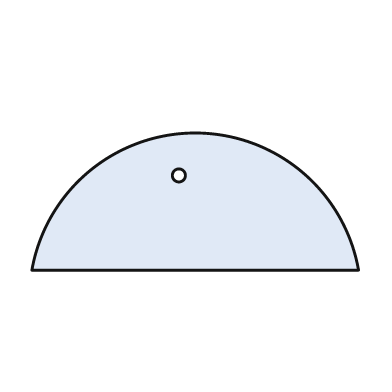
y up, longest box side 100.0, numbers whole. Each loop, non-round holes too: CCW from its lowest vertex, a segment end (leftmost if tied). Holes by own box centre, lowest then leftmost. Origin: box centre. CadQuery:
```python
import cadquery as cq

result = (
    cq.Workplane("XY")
    .moveTo(-50.0, -21.0)
    .lineTo(50.0, -21.0)
    .threePointArc((0.0, 21.0), (-50.0, -21.0))
    .close()
    .moveTo(-5.0, 8.0)
    .circle(2.0)
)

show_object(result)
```